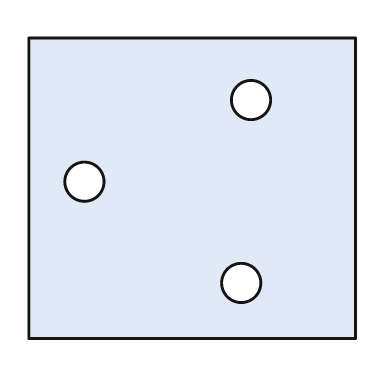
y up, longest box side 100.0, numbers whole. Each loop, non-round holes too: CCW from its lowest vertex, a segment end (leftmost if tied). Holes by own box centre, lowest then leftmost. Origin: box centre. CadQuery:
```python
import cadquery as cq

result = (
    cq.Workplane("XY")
    .moveTo(-50.0, -46.0)
    .lineTo(50.0, -46.0)
    .lineTo(50.0, 46.0)
    .lineTo(-50.0, 46.0)
    .close()
    .moveTo(15.0, -29.0)
    .circle(6.0)
    .moveTo(-33.0, 2.0)
    .circle(6.0)
    .moveTo(18.0, 27.0)
    .circle(6.0)
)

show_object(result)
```